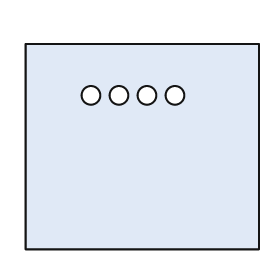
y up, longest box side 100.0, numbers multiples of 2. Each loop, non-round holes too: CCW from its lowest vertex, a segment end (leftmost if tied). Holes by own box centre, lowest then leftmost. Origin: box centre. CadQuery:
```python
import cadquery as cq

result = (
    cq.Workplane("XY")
    .moveTo(-50.0, -44.0)
    .lineTo(50.0, -44.0)
    .lineTo(50.0, 44.0)
    .lineTo(-50.0, 44.0)
    .close()
    .moveTo(-22.0, 22.0)
    .circle(4.0)
    .moveTo(-10.0, 22.0)
    .circle(4.0)
    .moveTo(2.0, 22.0)
    .circle(4.0)
    .moveTo(14.0, 22.0)
    .circle(4.0)
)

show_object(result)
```